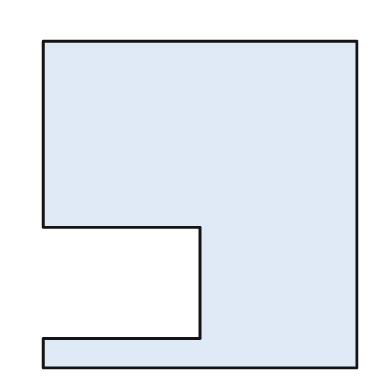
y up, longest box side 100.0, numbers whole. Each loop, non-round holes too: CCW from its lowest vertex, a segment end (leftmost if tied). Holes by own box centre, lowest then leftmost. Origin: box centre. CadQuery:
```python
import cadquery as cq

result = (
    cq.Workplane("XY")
    .moveTo(-48.0, -50.0)
    .lineTo(48.0, -50.0)
    .lineTo(48.0, 50.0)
    .lineTo(-48.0, 50.0)
    .lineTo(-48.0, -7.0)
    .lineTo(0.0, -7.0)
    .lineTo(0.0, -41.0)
    .lineTo(-48.0, -41.0)
    .close()
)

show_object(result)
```